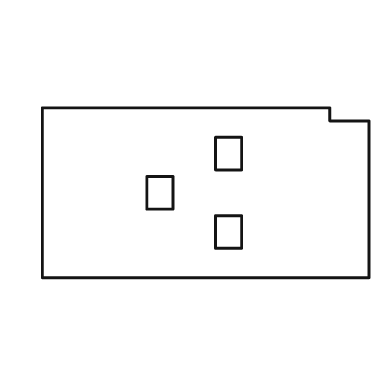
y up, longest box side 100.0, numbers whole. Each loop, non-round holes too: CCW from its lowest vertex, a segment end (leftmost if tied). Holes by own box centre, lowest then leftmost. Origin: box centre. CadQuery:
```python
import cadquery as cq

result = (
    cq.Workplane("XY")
    .moveTo(-50.0, -26.0)
    .lineTo(50.0, -26.0)
    .lineTo(50.0, 22.0)
    .lineTo(38.0, 22.0)
    .lineTo(38.0, 26.0)
    .lineTo(-50.0, 26.0)
    .close()
    .moveTo(3.0, -17.0)
    .lineTo(11.0, -17.0)
    .lineTo(11.0, -7.0)
    .lineTo(3.0, -7.0)
    .close()
    .moveTo(-18.0, -5.0)
    .lineTo(-10.0, -5.0)
    .lineTo(-10.0, 5.0)
    .lineTo(-18.0, 5.0)
    .close()
    .moveTo(3.0, 7.0)
    .lineTo(11.0, 7.0)
    .lineTo(11.0, 17.0)
    .lineTo(3.0, 17.0)
    .close()
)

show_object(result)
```